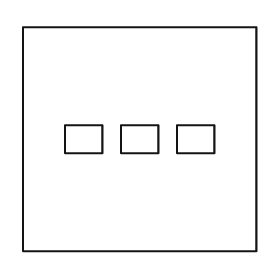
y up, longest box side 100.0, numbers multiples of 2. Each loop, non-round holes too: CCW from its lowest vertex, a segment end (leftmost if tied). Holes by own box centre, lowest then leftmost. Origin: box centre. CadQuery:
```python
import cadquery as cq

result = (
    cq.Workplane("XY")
    .moveTo(-50.0, -48.0)
    .lineTo(50.0, -48.0)
    .lineTo(50.0, 48.0)
    .lineTo(-50.0, 48.0)
    .close()
    .moveTo(-32.0, -6.0)
    .lineTo(-16.0, -6.0)
    .lineTo(-16.0, 6.0)
    .lineTo(-32.0, 6.0)
    .close()
    .moveTo(-8.0, -6.0)
    .lineTo(8.0, -6.0)
    .lineTo(8.0, 6.0)
    .lineTo(-8.0, 6.0)
    .close()
    .moveTo(16.0, -6.0)
    .lineTo(32.0, -6.0)
    .lineTo(32.0, 6.0)
    .lineTo(16.0, 6.0)
    .close()
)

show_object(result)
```